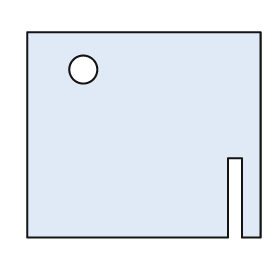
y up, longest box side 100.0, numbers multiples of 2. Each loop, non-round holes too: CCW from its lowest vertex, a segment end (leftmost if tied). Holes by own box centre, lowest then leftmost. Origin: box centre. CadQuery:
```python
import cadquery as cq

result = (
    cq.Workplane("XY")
    .moveTo(-50.0, -44.0)
    .lineTo(36.0, -44.0)
    .lineTo(36.0, -10.0)
    .lineTo(42.0, -10.0)
    .lineTo(42.0, -44.0)
    .lineTo(50.0, -44.0)
    .lineTo(50.0, 44.0)
    .lineTo(-50.0, 44.0)
    .close()
    .moveTo(-26.0, 28.0)
    .circle(6.0)
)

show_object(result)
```